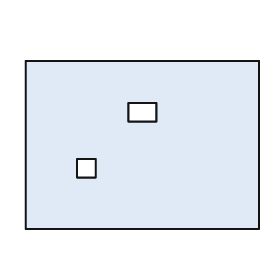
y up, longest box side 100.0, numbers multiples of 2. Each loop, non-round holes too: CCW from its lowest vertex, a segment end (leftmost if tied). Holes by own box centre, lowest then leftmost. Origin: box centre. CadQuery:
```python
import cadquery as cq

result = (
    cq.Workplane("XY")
    .moveTo(-50.0, -36.0)
    .lineTo(50.0, -36.0)
    .lineTo(50.0, 36.0)
    .lineTo(-50.0, 36.0)
    .close()
    .moveTo(-28.0, -14.0)
    .lineTo(-20.0, -14.0)
    .lineTo(-20.0, -6.0)
    .lineTo(-28.0, -6.0)
    .close()
    .moveTo(-6.0, 10.0)
    .lineTo(6.0, 10.0)
    .lineTo(6.0, 18.0)
    .lineTo(-6.0, 18.0)
    .close()
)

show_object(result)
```